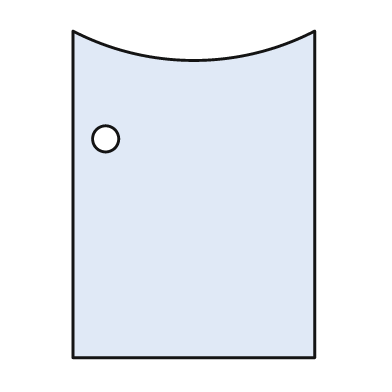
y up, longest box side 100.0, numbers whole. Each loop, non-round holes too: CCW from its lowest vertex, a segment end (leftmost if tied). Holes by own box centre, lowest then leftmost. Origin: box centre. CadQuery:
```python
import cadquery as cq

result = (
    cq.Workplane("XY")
    .moveTo(-37.0, -50.0)
    .lineTo(37.0, -50.0)
    .lineTo(37.0, 50.0)
    .threePointArc((0.0, 41.0), (-37.0, 50.0))
    .close()
    .moveTo(-27.0, 17.0)
    .circle(4.0)
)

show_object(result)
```